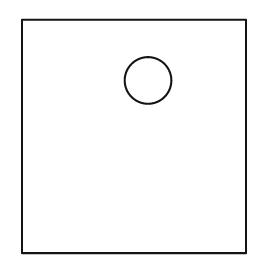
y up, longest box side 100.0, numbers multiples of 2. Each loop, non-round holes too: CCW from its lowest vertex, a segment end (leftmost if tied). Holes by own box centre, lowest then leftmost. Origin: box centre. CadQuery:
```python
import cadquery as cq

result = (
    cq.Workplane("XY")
    .moveTo(-48.0, -50.0)
    .lineTo(48.0, -50.0)
    .lineTo(48.0, 50.0)
    .lineTo(-48.0, 50.0)
    .close()
    .moveTo(6.0, 24.0)
    .circle(10.0)
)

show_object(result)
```